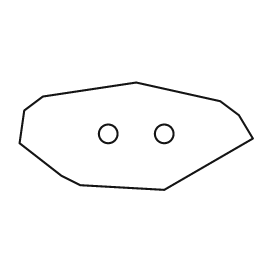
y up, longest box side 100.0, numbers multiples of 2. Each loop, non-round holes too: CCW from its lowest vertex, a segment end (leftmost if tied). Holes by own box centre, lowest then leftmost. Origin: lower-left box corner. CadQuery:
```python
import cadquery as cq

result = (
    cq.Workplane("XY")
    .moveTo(62.0, 0.0)
    .lineTo(100.0, 22.0)
    .lineTo(94.0, 32.0)
    .lineTo(86.0, 38.0)
    .lineTo(50.0, 46.0)
    .lineTo(10.0, 40.0)
    .lineTo(2.0, 34.0)
    .lineTo(0.0, 20.0)
    .lineTo(18.0, 6.0)
    .lineTo(26.0, 2.0)
    .close()
    .moveTo(38.0, 24.0)
    .circle(4.0)
    .moveTo(62.0, 24.0)
    .circle(4.0)
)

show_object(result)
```